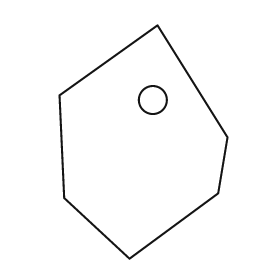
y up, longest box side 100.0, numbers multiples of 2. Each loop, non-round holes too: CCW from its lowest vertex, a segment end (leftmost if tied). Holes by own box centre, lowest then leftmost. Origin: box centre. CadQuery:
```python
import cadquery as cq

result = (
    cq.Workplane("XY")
    .moveTo(-6.0, -50.0)
    .lineTo(32.0, -22.0)
    .lineTo(36.0, 2.0)
    .lineTo(6.0, 50.0)
    .lineTo(-36.0, 20.0)
    .lineTo(-34.0, -24.0)
    .close()
    .moveTo(4.0, 18.0)
    .circle(6.0)
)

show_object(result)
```